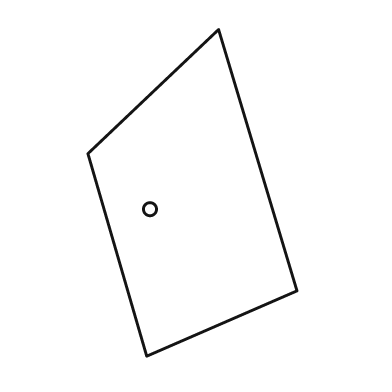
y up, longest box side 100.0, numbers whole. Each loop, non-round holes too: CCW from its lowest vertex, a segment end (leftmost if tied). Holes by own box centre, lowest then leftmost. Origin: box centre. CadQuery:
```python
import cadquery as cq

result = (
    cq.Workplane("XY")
    .moveTo(-14.0, -50.0)
    .lineTo(32.0, -30.0)
    .lineTo(8.0, 50.0)
    .lineTo(-32.0, 12.0)
    .close()
    .moveTo(-13.0, -5.0)
    .circle(2.0)
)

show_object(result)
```